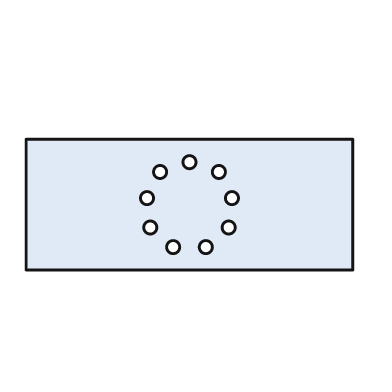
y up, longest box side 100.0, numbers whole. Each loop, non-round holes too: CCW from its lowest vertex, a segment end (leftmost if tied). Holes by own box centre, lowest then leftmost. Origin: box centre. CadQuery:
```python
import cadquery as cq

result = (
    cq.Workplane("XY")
    .moveTo(-50.0, -20.0)
    .lineTo(50.0, -20.0)
    .lineTo(50.0, 20.0)
    .lineTo(-50.0, 20.0)
    .close()
    .moveTo(-5.0, -13.0)
    .circle(2.0)
    .moveTo(5.0, -13.0)
    .circle(2.0)
    .moveTo(-12.0, -7.0)
    .circle(2.0)
    .moveTo(12.0, -7.0)
    .circle(2.0)
    .moveTo(-13.0, 2.0)
    .circle(2.0)
    .moveTo(13.0, 2.0)
    .circle(2.0)
    .moveTo(-9.0, 10.0)
    .circle(2.0)
    .moveTo(9.0, 10.0)
    .circle(2.0)
    .moveTo(0.0, 13.0)
    .circle(2.0)
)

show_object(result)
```